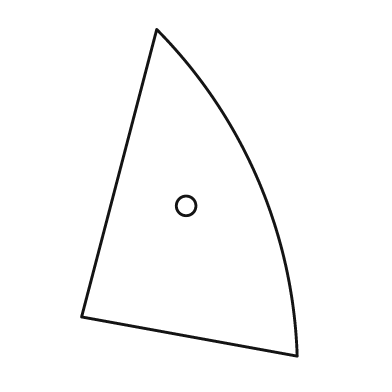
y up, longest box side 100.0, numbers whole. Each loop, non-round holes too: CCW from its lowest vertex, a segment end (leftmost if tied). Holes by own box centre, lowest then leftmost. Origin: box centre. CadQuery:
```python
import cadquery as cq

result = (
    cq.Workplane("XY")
    .moveTo(33.0, -50.0)
    .threePointArc((21.0, 4.0), (-10.0, 50.0))
    .lineTo(-33.0, -38.0)
    .close()
    .moveTo(-1.0, -4.0)
    .circle(3.0)
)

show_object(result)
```